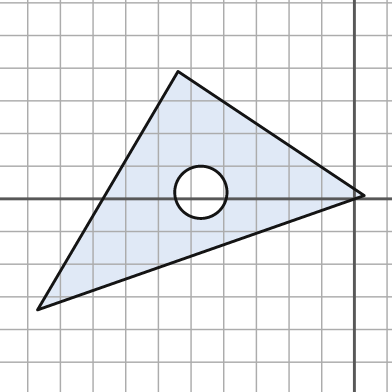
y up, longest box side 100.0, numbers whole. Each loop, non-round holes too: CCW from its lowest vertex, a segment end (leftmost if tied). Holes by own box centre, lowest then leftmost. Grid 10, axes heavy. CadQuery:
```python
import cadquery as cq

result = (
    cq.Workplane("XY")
    .moveTo(-97.0, -34.0)
    .lineTo(3.0, 1.0)
    .lineTo(-54.0, 39.0)
    .close()
    .moveTo(-47.0, 2.0)
    .circle(8.0)
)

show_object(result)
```